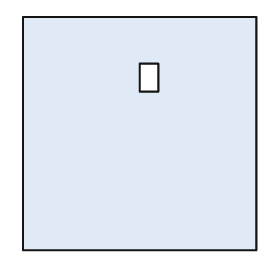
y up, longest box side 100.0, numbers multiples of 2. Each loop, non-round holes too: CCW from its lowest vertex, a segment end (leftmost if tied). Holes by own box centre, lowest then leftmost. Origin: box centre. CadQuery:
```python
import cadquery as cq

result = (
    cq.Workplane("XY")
    .moveTo(-50.0, -50.0)
    .lineTo(50.0, -50.0)
    .lineTo(50.0, 50.0)
    .lineTo(-50.0, 50.0)
    .close()
    .moveTo(0.0, 18.0)
    .lineTo(8.0, 18.0)
    .lineTo(8.0, 30.0)
    .lineTo(0.0, 30.0)
    .close()
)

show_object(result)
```